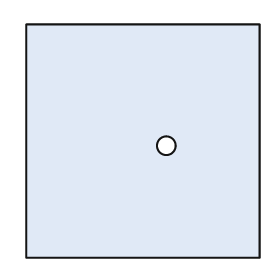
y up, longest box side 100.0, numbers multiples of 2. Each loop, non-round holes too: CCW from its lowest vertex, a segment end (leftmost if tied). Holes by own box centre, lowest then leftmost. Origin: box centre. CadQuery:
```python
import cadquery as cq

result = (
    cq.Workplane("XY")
    .moveTo(-50.0, -50.0)
    .lineTo(50.0, -50.0)
    .lineTo(50.0, 50.0)
    .lineTo(-50.0, 50.0)
    .close()
    .moveTo(10.0, -2.0)
    .circle(4.0)
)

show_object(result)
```